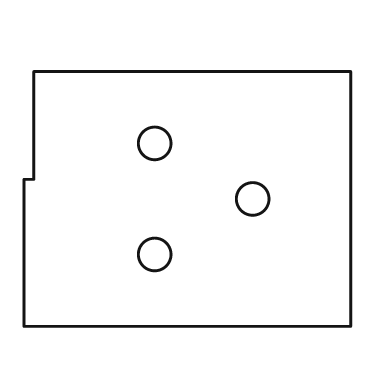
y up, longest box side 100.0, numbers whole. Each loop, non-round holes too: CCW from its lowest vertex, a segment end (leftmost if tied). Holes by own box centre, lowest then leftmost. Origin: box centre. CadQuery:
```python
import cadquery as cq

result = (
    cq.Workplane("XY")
    .moveTo(-50.0, -39.0)
    .lineTo(50.0, -39.0)
    .lineTo(50.0, 39.0)
    .lineTo(-47.0, 39.0)
    .lineTo(-47.0, 6.0)
    .lineTo(-50.0, 6.0)
    .close()
    .moveTo(-10.0, -17.0)
    .circle(5.0)
    .moveTo(20.0, 0.0)
    .circle(5.0)
    .moveTo(-10.0, 17.0)
    .circle(5.0)
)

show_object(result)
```